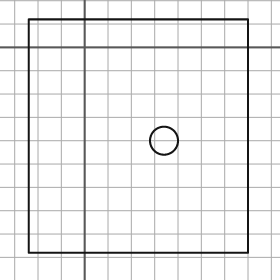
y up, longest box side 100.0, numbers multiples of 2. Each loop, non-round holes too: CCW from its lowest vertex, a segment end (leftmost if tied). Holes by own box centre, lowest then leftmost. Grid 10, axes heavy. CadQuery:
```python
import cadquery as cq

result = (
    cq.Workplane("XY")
    .moveTo(-24.0, -88.0)
    .lineTo(70.0, -88.0)
    .lineTo(70.0, 12.0)
    .lineTo(-24.0, 12.0)
    .close()
    .moveTo(34.0, -40.0)
    .circle(6.0)
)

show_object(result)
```